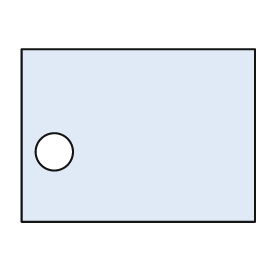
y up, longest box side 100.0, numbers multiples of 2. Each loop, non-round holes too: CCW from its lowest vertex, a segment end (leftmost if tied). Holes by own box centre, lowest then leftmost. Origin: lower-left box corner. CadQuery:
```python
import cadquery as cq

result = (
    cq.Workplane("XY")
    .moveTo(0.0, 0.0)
    .lineTo(100.0, 0.0)
    .lineTo(100.0, 74.0)
    .lineTo(0.0, 74.0)
    .close()
    .moveTo(14.0, 30.0)
    .circle(8.0)
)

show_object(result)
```